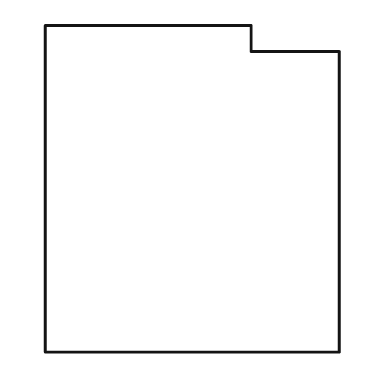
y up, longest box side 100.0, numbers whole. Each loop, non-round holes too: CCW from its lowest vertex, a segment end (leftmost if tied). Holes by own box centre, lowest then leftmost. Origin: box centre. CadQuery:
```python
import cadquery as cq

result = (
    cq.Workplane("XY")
    .moveTo(-45.0, -50.0)
    .lineTo(45.0, -50.0)
    .lineTo(45.0, 42.0)
    .lineTo(18.0, 42.0)
    .lineTo(18.0, 50.0)
    .lineTo(-45.0, 50.0)
    .close()
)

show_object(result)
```